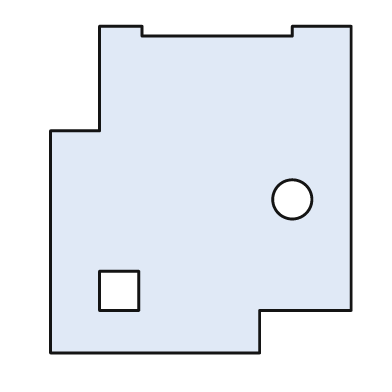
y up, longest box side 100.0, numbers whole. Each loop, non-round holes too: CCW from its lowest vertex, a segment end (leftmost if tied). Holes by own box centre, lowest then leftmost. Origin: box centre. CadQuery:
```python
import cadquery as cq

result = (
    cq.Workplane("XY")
    .moveTo(-46.0, -50.0)
    .lineTo(18.0, -50.0)
    .lineTo(18.0, -37.0)
    .lineTo(46.0, -37.0)
    .lineTo(46.0, 50.0)
    .lineTo(28.0, 50.0)
    .lineTo(28.0, 47.0)
    .lineTo(-18.0, 47.0)
    .lineTo(-18.0, 50.0)
    .lineTo(-31.0, 50.0)
    .lineTo(-31.0, 18.0)
    .lineTo(-46.0, 18.0)
    .close()
    .moveTo(-31.0, -37.0)
    .lineTo(-19.0, -37.0)
    .lineTo(-19.0, -25.0)
    .lineTo(-31.0, -25.0)
    .close()
    .moveTo(28.0, -3.0)
    .circle(6.0)
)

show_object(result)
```